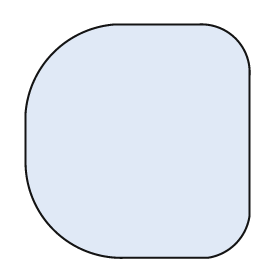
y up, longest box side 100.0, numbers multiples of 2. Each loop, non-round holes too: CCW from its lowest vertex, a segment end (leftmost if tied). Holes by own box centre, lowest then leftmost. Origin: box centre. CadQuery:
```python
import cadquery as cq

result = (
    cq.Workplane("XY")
    .moveTo(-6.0, -50.0)
    .lineTo(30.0, -50.0)
    .threePointArc((42.0, -44.0), (48.0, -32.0))
    .lineTo(48.0, 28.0)
    .threePointArc((42.0, 44.0), (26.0, 50.0))
    .lineTo(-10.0, 50.0)
    .threePointArc((-36.0, 38.0), (-48.0, 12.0))
    .lineTo(-48.0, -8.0)
    .threePointArc((-36.0, -38.0), (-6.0, -50.0))
    .close()
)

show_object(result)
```